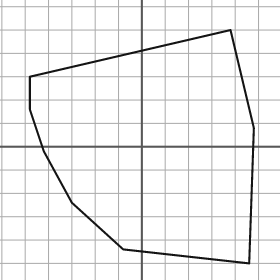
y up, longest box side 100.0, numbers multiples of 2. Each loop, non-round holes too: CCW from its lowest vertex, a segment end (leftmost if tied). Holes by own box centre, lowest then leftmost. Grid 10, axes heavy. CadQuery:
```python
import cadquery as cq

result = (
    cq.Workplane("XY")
    .moveTo(46.0, -50.0)
    .lineTo(48.0, 8.0)
    .lineTo(38.0, 50.0)
    .lineTo(-48.0, 30.0)
    .lineTo(-48.0, 16.0)
    .lineTo(-42.0, -2.0)
    .lineTo(-30.0, -24.0)
    .lineTo(-8.0, -44.0)
    .close()
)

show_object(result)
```